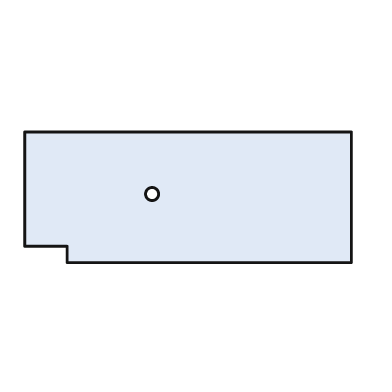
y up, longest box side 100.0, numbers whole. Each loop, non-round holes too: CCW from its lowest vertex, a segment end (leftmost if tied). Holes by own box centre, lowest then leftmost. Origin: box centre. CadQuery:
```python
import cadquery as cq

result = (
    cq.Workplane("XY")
    .moveTo(-37.0, -20.0)
    .lineTo(50.0, -20.0)
    .lineTo(50.0, 20.0)
    .lineTo(-50.0, 20.0)
    .lineTo(-50.0, -15.0)
    .lineTo(-37.0, -15.0)
    .close()
    .moveTo(-11.0, 1.0)
    .circle(2.0)
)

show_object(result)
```